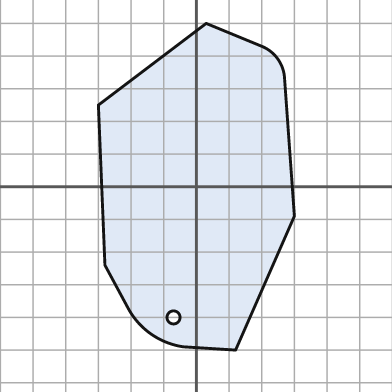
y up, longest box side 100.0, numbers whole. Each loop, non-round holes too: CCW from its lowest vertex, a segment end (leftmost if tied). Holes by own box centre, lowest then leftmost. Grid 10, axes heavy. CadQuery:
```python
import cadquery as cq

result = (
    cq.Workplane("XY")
    .moveTo(12.0, -50.0)
    .lineTo(30.0, -9.0)
    .lineTo(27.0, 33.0)
    .threePointArc((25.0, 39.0), (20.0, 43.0))
    .lineTo(3.0, 50.0)
    .lineTo(-30.0, 25.0)
    .lineTo(-28.0, -24.0)
    .lineTo(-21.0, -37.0)
    .threePointArc((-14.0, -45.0), (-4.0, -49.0))
    .close()
    .moveTo(-7.0, -40.0)
    .circle(2.0)
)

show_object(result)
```